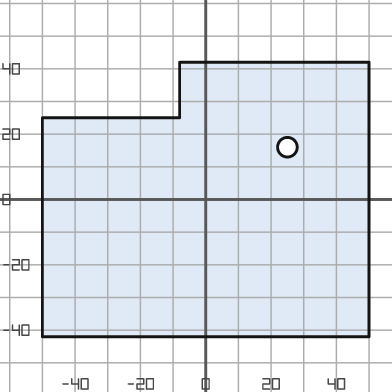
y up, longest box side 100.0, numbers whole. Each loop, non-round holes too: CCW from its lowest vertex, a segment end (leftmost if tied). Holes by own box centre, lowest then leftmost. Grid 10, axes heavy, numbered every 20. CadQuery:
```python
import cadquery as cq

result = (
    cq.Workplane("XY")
    .moveTo(-50.0, -42.0)
    .lineTo(50.0, -42.0)
    .lineTo(50.0, 42.0)
    .lineTo(-8.0, 42.0)
    .lineTo(-8.0, 25.0)
    .lineTo(-50.0, 25.0)
    .close()
    .moveTo(25.0, 16.0)
    .circle(3.0)
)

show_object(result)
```